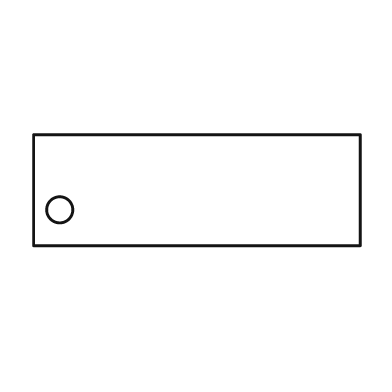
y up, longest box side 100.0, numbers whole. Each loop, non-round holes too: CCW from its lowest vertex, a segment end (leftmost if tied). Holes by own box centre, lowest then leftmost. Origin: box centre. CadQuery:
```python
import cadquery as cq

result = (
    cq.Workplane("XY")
    .moveTo(-50.0, -17.0)
    .lineTo(50.0, -17.0)
    .lineTo(50.0, 17.0)
    .lineTo(-50.0, 17.0)
    .close()
    .moveTo(-42.0, -6.0)
    .circle(4.0)
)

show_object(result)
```